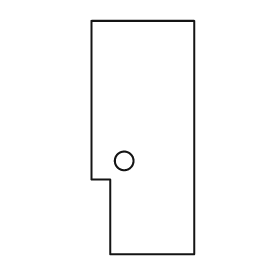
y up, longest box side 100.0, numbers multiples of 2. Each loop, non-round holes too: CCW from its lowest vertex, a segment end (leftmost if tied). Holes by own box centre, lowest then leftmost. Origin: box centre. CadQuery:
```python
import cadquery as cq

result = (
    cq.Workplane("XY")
    .moveTo(-14.0, -50.0)
    .lineTo(22.0, -50.0)
    .lineTo(22.0, 50.0)
    .lineTo(-22.0, 50.0)
    .lineTo(-22.0, -18.0)
    .lineTo(-14.0, -18.0)
    .close()
    .moveTo(-8.0, -10.0)
    .circle(4.0)
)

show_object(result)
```